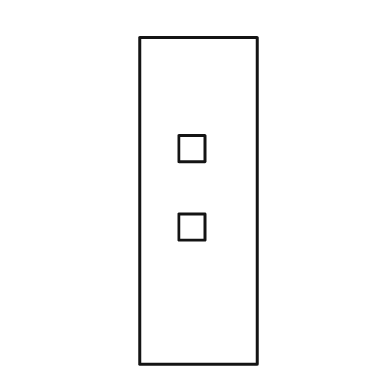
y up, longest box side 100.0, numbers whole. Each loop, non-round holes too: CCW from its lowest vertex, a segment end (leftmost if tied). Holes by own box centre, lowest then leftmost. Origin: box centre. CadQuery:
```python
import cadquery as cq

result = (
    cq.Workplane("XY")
    .moveTo(-18.0, -50.0)
    .lineTo(18.0, -50.0)
    .lineTo(18.0, 50.0)
    .lineTo(-18.0, 50.0)
    .close()
    .moveTo(-6.0, -12.0)
    .lineTo(2.0, -12.0)
    .lineTo(2.0, -4.0)
    .lineTo(-6.0, -4.0)
    .close()
    .moveTo(-6.0, 12.0)
    .lineTo(2.0, 12.0)
    .lineTo(2.0, 20.0)
    .lineTo(-6.0, 20.0)
    .close()
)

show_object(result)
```